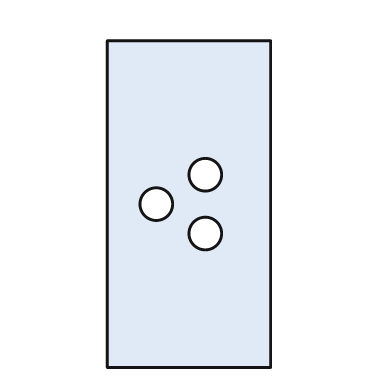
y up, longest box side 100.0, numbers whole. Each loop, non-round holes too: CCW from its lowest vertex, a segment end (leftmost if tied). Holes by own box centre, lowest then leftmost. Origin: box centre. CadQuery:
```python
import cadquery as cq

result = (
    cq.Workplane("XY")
    .moveTo(-25.0, -50.0)
    .lineTo(25.0, -50.0)
    .lineTo(25.0, 50.0)
    .lineTo(-25.0, 50.0)
    .close()
    .moveTo(5.0, -9.0)
    .circle(5.0)
    .moveTo(-10.0, 0.0)
    .circle(5.0)
    .moveTo(5.0, 9.0)
    .circle(5.0)
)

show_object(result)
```